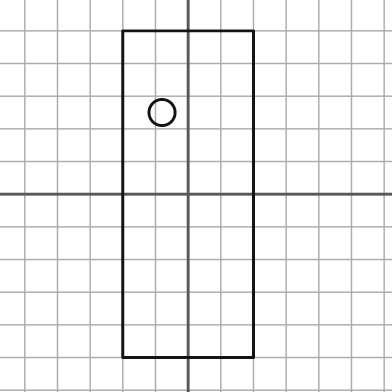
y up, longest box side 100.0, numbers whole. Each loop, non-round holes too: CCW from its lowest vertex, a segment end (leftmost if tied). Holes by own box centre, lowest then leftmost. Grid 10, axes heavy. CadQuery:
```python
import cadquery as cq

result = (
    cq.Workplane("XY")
    .moveTo(-20.0, -50.0)
    .lineTo(20.0, -50.0)
    .lineTo(20.0, 50.0)
    .lineTo(-20.0, 50.0)
    .close()
    .moveTo(-8.0, 25.0)
    .circle(4.0)
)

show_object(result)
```